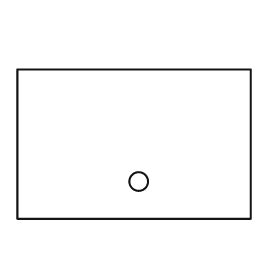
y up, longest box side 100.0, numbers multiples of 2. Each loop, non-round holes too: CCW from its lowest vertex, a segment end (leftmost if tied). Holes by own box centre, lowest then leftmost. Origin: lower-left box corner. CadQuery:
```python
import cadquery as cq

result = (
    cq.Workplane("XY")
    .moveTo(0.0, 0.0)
    .lineTo(100.0, 0.0)
    .lineTo(100.0, 64.0)
    .lineTo(0.0, 64.0)
    .close()
    .moveTo(52.0, 16.0)
    .circle(4.0)
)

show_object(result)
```